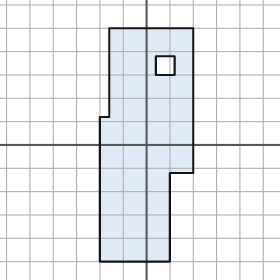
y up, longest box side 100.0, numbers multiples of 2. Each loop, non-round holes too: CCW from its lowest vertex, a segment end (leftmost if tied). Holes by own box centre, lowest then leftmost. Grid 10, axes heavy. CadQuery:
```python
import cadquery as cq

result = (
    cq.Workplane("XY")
    .moveTo(-20.0, -50.0)
    .lineTo(10.0, -50.0)
    .lineTo(10.0, -12.0)
    .lineTo(20.0, -12.0)
    .lineTo(20.0, 50.0)
    .lineTo(-16.0, 50.0)
    .lineTo(-16.0, 12.0)
    .lineTo(-20.0, 12.0)
    .close()
    .moveTo(4.0, 30.0)
    .lineTo(12.0, 30.0)
    .lineTo(12.0, 38.0)
    .lineTo(4.0, 38.0)
    .close()
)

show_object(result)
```